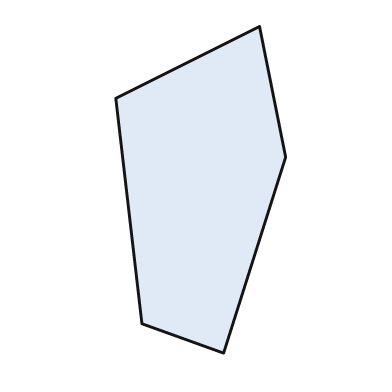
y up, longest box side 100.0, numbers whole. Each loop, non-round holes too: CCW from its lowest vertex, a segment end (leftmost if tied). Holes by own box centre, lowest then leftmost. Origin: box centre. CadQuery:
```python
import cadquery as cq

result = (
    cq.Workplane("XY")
    .moveTo(7.0, -50.0)
    .lineTo(26.0, 10.0)
    .lineTo(18.0, 50.0)
    .lineTo(-26.0, 28.0)
    .lineTo(-18.0, -41.0)
    .close()
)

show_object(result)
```